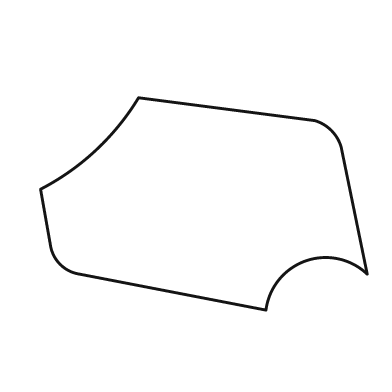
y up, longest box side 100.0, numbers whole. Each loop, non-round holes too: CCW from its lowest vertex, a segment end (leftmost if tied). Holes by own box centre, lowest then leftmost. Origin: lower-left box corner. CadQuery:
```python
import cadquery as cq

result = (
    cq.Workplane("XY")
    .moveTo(69.0, 0.0)
    .threePointArc((81.0, 15.0), (100.0, 11.0))
    .lineTo(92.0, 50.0)
    .threePointArc((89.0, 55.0), (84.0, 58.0))
    .lineTo(30.0, 65.0)
    .threePointArc((17.0, 49.0), (0.0, 37.0))
    .lineTo(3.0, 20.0)
    .threePointArc((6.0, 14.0), (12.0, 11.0))
    .close()
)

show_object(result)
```